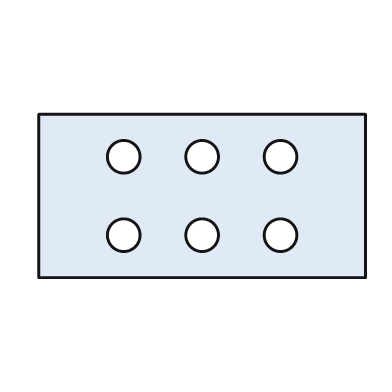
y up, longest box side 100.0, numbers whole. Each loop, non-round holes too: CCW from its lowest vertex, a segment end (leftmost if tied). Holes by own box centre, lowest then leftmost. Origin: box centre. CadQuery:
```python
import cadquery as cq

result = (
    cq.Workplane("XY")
    .moveTo(-50.0, -25.0)
    .lineTo(50.0, -25.0)
    .lineTo(50.0, 25.0)
    .lineTo(-50.0, 25.0)
    .close()
    .moveTo(-24.0, -12.0)
    .circle(5.0)
    .moveTo(0.0, -12.0)
    .circle(5.0)
    .moveTo(24.0, -12.0)
    .circle(5.0)
    .moveTo(-24.0, 12.0)
    .circle(5.0)
    .moveTo(0.0, 12.0)
    .circle(5.0)
    .moveTo(24.0, 12.0)
    .circle(5.0)
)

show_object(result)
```